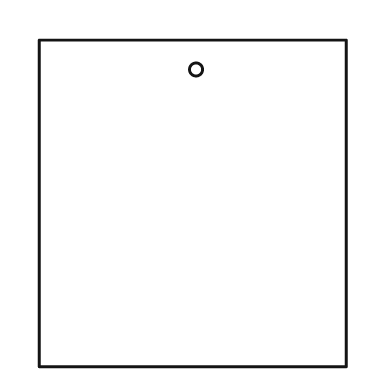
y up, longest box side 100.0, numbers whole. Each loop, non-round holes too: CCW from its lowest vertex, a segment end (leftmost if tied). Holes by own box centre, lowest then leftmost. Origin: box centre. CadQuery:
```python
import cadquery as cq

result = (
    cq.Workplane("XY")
    .moveTo(-47.0, -50.0)
    .lineTo(47.0, -50.0)
    .lineTo(47.0, 50.0)
    .lineTo(-47.0, 50.0)
    .close()
    .moveTo(1.0, 41.0)
    .circle(2.0)
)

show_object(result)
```